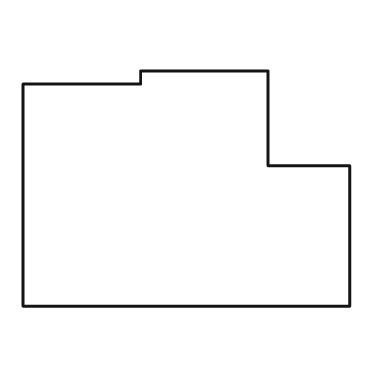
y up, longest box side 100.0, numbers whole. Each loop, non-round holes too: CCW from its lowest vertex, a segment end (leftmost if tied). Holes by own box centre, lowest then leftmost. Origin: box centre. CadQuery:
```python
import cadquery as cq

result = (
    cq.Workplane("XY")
    .moveTo(-50.0, -36.0)
    .lineTo(50.0, -36.0)
    .lineTo(50.0, 7.0)
    .lineTo(25.0, 7.0)
    .lineTo(25.0, 36.0)
    .lineTo(-14.0, 36.0)
    .lineTo(-14.0, 32.0)
    .lineTo(-50.0, 32.0)
    .close()
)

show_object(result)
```